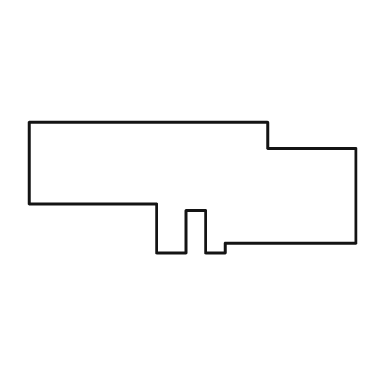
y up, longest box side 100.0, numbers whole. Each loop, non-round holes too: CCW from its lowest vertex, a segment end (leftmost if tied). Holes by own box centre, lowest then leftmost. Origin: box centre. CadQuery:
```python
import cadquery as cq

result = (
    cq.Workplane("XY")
    .moveTo(-11.0, -20.0)
    .lineTo(-2.0, -20.0)
    .lineTo(-2.0, -7.0)
    .lineTo(4.0, -7.0)
    .lineTo(4.0, -20.0)
    .lineTo(10.0, -20.0)
    .lineTo(10.0, -17.0)
    .lineTo(50.0, -17.0)
    .lineTo(50.0, 12.0)
    .lineTo(23.0, 12.0)
    .lineTo(23.0, 20.0)
    .lineTo(-50.0, 20.0)
    .lineTo(-50.0, -5.0)
    .lineTo(-11.0, -5.0)
    .close()
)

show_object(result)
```